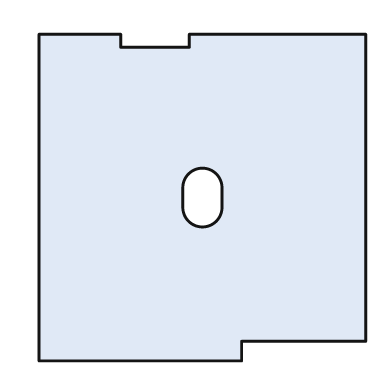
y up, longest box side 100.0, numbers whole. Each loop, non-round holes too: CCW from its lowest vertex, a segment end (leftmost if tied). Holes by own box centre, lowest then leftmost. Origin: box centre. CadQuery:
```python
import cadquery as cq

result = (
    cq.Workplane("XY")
    .moveTo(-50.0, -50.0)
    .lineTo(12.0, -50.0)
    .lineTo(12.0, -44.0)
    .lineTo(50.0, -44.0)
    .lineTo(50.0, 50.0)
    .lineTo(-4.0, 50.0)
    .lineTo(-4.0, 46.0)
    .lineTo(-25.0, 46.0)
    .lineTo(-25.0, 50.0)
    .lineTo(-50.0, 50.0)
    .close()
    .moveTo(-6.0, -3.0)
    .threePointArc((0.0, -9.0), (6.0, -3.0))
    .lineTo(6.0, 3.0)
    .threePointArc((0.0, 9.0), (-6.0, 3.0))
    .close()
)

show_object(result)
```